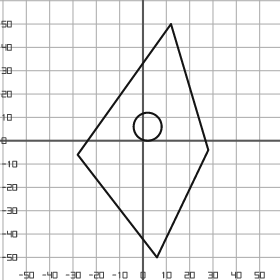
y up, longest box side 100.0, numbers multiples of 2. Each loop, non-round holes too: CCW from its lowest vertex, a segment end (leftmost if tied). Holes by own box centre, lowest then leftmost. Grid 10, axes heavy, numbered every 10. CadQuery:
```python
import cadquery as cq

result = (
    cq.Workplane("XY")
    .moveTo(6.0, -50.0)
    .lineTo(28.0, -4.0)
    .lineTo(12.0, 50.0)
    .lineTo(-28.0, -6.0)
    .close()
    .moveTo(2.0, 6.0)
    .circle(6.0)
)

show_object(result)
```